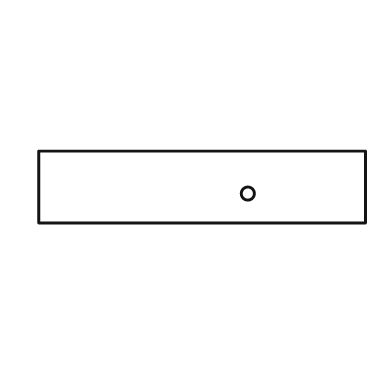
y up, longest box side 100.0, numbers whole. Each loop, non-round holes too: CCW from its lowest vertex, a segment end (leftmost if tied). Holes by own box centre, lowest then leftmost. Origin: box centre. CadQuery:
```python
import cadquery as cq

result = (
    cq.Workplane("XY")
    .moveTo(-50.0, -11.0)
    .lineTo(50.0, -11.0)
    .lineTo(50.0, 11.0)
    .lineTo(-50.0, 11.0)
    .close()
    .moveTo(14.0, -2.0)
    .circle(2.0)
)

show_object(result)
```